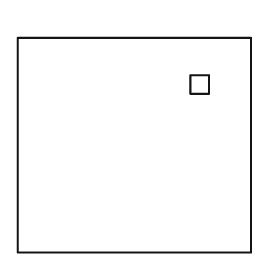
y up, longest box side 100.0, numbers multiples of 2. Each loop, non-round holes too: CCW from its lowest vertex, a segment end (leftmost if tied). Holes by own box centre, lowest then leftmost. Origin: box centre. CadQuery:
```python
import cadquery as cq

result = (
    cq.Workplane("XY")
    .moveTo(-50.0, -46.0)
    .lineTo(50.0, -46.0)
    .lineTo(50.0, 46.0)
    .lineTo(-50.0, 46.0)
    .close()
    .moveTo(24.0, 22.0)
    .lineTo(32.0, 22.0)
    .lineTo(32.0, 30.0)
    .lineTo(24.0, 30.0)
    .close()
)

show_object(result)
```